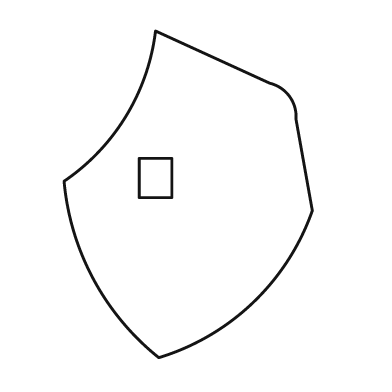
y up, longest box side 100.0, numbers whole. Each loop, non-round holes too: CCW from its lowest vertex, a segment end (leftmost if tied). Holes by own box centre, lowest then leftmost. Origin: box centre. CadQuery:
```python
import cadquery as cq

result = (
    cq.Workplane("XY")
    .moveTo(-9.0, -50.0)
    .threePointArc((20.0, -33.0), (38.0, -5.0))
    .lineTo(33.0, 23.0)
    .threePointArc((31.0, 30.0), (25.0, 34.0))
    .lineTo(-10.0, 50.0)
    .threePointArc((-19.0, 24.0), (-38.0, 4.0))
    .threePointArc((-29.0, -26.0), (-9.0, -50.0))
    .close()
    .moveTo(-15.0, -1.0)
    .lineTo(-5.0, -1.0)
    .lineTo(-5.0, 11.0)
    .lineTo(-15.0, 11.0)
    .close()
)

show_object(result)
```